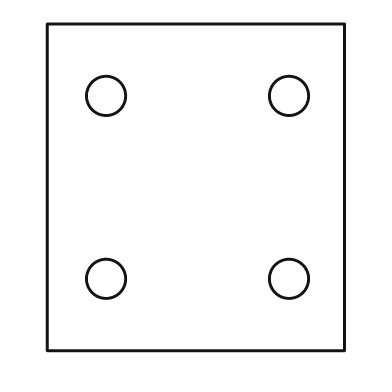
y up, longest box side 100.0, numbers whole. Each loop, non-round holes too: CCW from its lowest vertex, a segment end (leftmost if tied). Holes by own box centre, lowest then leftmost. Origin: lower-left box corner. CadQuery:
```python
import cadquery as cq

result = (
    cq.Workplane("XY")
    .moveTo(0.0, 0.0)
    .lineTo(91.0, 0.0)
    .lineTo(91.0, 100.0)
    .lineTo(0.0, 100.0)
    .close()
    .moveTo(18.0, 22.0)
    .circle(6.0)
    .moveTo(74.0, 22.0)
    .circle(6.0)
    .moveTo(18.0, 78.0)
    .circle(6.0)
    .moveTo(74.0, 78.0)
    .circle(6.0)
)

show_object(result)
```